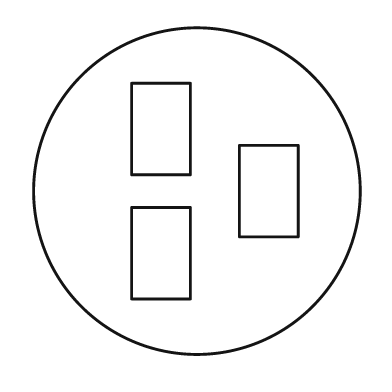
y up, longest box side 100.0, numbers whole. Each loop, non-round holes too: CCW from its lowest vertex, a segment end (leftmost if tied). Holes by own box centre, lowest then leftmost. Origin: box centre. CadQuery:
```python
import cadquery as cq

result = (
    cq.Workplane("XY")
    .moveTo(0.0, 0.0)
    .circle(50.0)
    .moveTo(-20.0, -33.0)
    .lineTo(-2.0, -33.0)
    .lineTo(-2.0, -5.0)
    .lineTo(-20.0, -5.0)
    .close()
    .moveTo(13.0, -14.0)
    .lineTo(31.0, -14.0)
    .lineTo(31.0, 14.0)
    .lineTo(13.0, 14.0)
    .close()
    .moveTo(-20.0, 5.0)
    .lineTo(-2.0, 5.0)
    .lineTo(-2.0, 33.0)
    .lineTo(-20.0, 33.0)
    .close()
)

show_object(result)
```